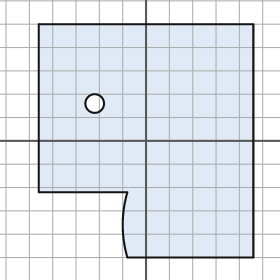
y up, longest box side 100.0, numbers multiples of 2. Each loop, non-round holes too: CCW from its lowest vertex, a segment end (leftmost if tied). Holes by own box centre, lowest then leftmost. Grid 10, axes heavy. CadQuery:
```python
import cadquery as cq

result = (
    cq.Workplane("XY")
    .moveTo(-8.0, -50.0)
    .lineTo(46.0, -50.0)
    .lineTo(46.0, 50.0)
    .lineTo(-46.0, 50.0)
    .lineTo(-46.0, -22.0)
    .lineTo(-8.0, -22.0)
    .threePointArc((-10.0, -36.0), (-8.0, -50.0))
    .close()
    .moveTo(-22.0, 16.0)
    .circle(4.0)
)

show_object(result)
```